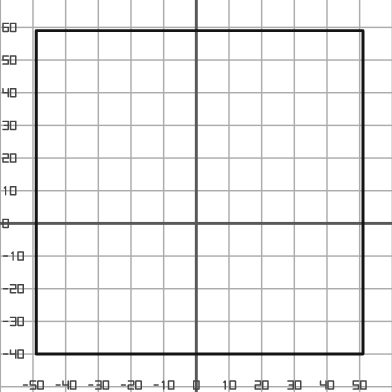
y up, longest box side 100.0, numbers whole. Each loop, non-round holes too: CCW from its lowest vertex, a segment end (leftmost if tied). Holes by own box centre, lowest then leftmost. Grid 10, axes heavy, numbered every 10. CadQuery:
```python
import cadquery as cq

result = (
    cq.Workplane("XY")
    .moveTo(-49.0, -40.0)
    .lineTo(51.0, -40.0)
    .lineTo(51.0, 59.0)
    .lineTo(-49.0, 59.0)
    .close()
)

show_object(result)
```